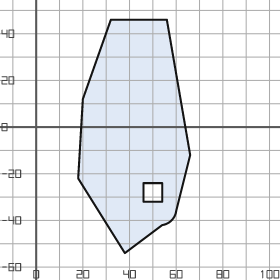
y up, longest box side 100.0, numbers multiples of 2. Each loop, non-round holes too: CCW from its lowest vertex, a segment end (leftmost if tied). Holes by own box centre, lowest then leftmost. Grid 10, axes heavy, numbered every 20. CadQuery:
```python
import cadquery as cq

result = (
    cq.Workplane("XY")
    .moveTo(38.0, -54.0)
    .lineTo(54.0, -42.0)
    .threePointArc((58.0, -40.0), (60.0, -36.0))
    .lineTo(66.0, -12.0)
    .lineTo(56.0, 46.0)
    .lineTo(32.0, 46.0)
    .lineTo(20.0, 12.0)
    .lineTo(18.0, -22.0)
    .close()
    .moveTo(46.0, -32.0)
    .lineTo(54.0, -32.0)
    .lineTo(54.0, -24.0)
    .lineTo(46.0, -24.0)
    .close()
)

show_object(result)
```